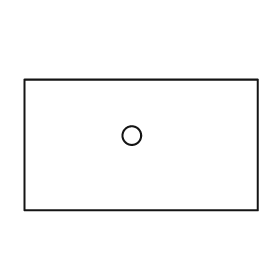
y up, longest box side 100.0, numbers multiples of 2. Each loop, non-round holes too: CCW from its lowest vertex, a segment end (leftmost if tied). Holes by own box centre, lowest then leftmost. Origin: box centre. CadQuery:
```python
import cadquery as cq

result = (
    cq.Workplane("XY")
    .moveTo(-50.0, -28.0)
    .lineTo(50.0, -28.0)
    .lineTo(50.0, 28.0)
    .lineTo(-50.0, 28.0)
    .close()
    .moveTo(-4.0, 4.0)
    .circle(4.0)
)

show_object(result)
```